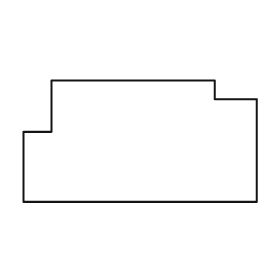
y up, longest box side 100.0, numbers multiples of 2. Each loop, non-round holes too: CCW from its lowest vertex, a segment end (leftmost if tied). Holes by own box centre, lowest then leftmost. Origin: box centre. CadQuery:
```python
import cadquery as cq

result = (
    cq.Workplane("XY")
    .moveTo(-50.0, -26.0)
    .lineTo(50.0, -26.0)
    .lineTo(50.0, 18.0)
    .lineTo(32.0, 18.0)
    .lineTo(32.0, 26.0)
    .lineTo(-38.0, 26.0)
    .lineTo(-38.0, 4.0)
    .lineTo(-50.0, 4.0)
    .close()
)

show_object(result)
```